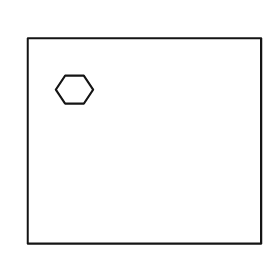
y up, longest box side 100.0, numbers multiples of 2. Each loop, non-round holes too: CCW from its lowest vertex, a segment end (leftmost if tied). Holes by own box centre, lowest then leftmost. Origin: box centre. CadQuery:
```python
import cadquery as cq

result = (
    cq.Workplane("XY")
    .moveTo(-50.0, -44.0)
    .lineTo(50.0, -44.0)
    .lineTo(50.0, 44.0)
    .lineTo(-50.0, 44.0)
    .close()
    .moveTo(-34.0, 16.0)
    .lineTo(-26.0, 16.0)
    .lineTo(-22.0, 22.0)
    .lineTo(-26.0, 28.0)
    .lineTo(-34.0, 28.0)
    .lineTo(-38.0, 22.0)
    .close()
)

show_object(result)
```